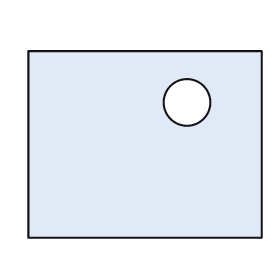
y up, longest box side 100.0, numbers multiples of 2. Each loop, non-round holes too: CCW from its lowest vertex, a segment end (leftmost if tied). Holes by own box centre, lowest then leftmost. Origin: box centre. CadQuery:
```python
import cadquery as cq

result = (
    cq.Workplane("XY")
    .moveTo(-50.0, -40.0)
    .lineTo(50.0, -40.0)
    .lineTo(50.0, 40.0)
    .lineTo(-50.0, 40.0)
    .close()
    .moveTo(18.0, 18.0)
    .circle(10.0)
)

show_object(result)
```